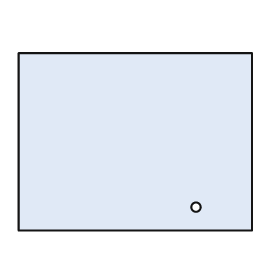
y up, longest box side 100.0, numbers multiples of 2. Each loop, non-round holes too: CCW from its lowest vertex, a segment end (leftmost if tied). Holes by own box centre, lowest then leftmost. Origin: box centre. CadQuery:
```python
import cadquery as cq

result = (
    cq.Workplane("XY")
    .moveTo(-50.0, -38.0)
    .lineTo(50.0, -38.0)
    .lineTo(50.0, 38.0)
    .lineTo(-50.0, 38.0)
    .close()
    .moveTo(26.0, -28.0)
    .circle(2.0)
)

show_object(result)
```